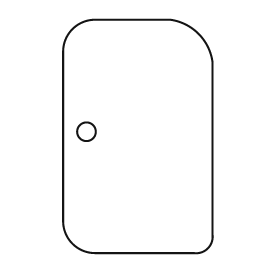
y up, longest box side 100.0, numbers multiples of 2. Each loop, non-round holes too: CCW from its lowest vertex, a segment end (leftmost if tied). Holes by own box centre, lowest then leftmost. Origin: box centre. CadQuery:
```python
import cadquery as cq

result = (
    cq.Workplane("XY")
    .moveTo(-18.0, -50.0)
    .lineTo(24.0, -50.0)
    .threePointArc((30.0, -48.0), (32.0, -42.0))
    .lineTo(32.0, 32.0)
    .threePointArc((26.0, 44.0), (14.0, 50.0))
    .lineTo(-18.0, 50.0)
    .threePointArc((-28.0, 46.0), (-32.0, 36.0))
    .lineTo(-32.0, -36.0)
    .threePointArc((-28.0, -46.0), (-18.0, -50.0))
    .close()
    .moveTo(-22.0, 2.0)
    .circle(4.0)
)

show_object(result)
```